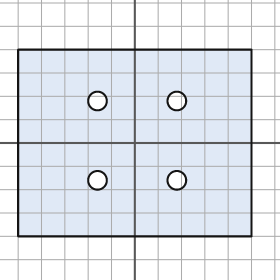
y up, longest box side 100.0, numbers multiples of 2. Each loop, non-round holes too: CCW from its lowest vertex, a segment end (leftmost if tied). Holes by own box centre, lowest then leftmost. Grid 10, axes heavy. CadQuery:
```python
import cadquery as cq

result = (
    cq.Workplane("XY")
    .moveTo(-50.0, -40.0)
    .lineTo(50.0, -40.0)
    .lineTo(50.0, 40.0)
    .lineTo(-50.0, 40.0)
    .close()
    .moveTo(-16.0, -16.0)
    .circle(4.0)
    .moveTo(18.0, -16.0)
    .circle(4.0)
    .moveTo(-16.0, 18.0)
    .circle(4.0)
    .moveTo(18.0, 18.0)
    .circle(4.0)
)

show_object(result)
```